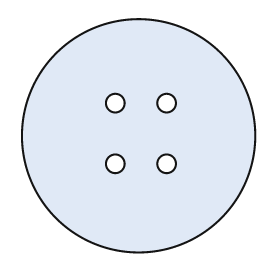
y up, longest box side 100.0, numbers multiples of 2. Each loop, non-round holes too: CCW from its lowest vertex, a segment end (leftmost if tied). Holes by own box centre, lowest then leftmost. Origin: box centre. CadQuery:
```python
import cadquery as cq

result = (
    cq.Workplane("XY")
    .moveTo(0.0, 0.0)
    .circle(50.0)
    .moveTo(-10.0, -12.0)
    .circle(4.0)
    .moveTo(12.0, -12.0)
    .circle(4.0)
    .moveTo(-10.0, 14.0)
    .circle(4.0)
    .moveTo(12.0, 14.0)
    .circle(4.0)
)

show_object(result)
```